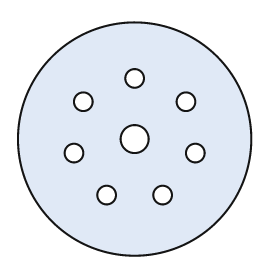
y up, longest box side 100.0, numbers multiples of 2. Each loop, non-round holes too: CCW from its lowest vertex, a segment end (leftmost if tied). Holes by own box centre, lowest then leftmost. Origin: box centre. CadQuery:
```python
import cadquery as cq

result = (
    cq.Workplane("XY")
    .moveTo(0.0, 0.0)
    .circle(50.0)
    .moveTo(-12.0, -24.0)
    .circle(4.0)
    .moveTo(12.0, -24.0)
    .circle(4.0)
    .moveTo(-26.0, -6.0)
    .circle(4.0)
    .moveTo(26.0, -6.0)
    .circle(4.0)
    .moveTo(0.0, 0.0)
    .circle(6.0)
    .moveTo(-22.0, 16.0)
    .circle(4.0)
    .moveTo(22.0, 16.0)
    .circle(4.0)
    .moveTo(0.0, 26.0)
    .circle(4.0)
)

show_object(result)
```